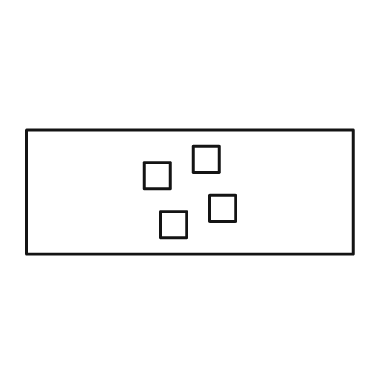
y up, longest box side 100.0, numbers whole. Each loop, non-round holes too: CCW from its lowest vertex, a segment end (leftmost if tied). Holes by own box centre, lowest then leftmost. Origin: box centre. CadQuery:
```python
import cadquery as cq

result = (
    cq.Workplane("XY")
    .moveTo(-50.0, -19.0)
    .lineTo(50.0, -19.0)
    .lineTo(50.0, 19.0)
    .lineTo(-50.0, 19.0)
    .close()
    .moveTo(-9.0, -14.0)
    .lineTo(-1.0, -14.0)
    .lineTo(-1.0, -6.0)
    .lineTo(-9.0, -6.0)
    .close()
    .moveTo(6.0, -9.0)
    .lineTo(14.0, -9.0)
    .lineTo(14.0, -1.0)
    .lineTo(6.0, -1.0)
    .close()
    .moveTo(-14.0, 1.0)
    .lineTo(-6.0, 1.0)
    .lineTo(-6.0, 9.0)
    .lineTo(-14.0, 9.0)
    .close()
    .moveTo(1.0, 6.0)
    .lineTo(9.0, 6.0)
    .lineTo(9.0, 14.0)
    .lineTo(1.0, 14.0)
    .close()
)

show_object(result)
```